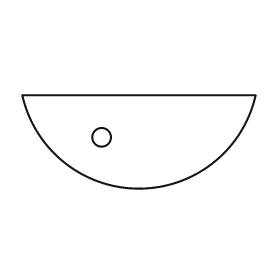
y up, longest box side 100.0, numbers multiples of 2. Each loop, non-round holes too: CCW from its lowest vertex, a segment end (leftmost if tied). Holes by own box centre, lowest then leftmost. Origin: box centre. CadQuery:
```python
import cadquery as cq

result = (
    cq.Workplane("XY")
    .moveTo(-50.0, 20.0)
    .threePointArc((0.0, -20.0), (50.0, 20.0))
    .close()
    .moveTo(-16.0, 2.0)
    .circle(4.0)
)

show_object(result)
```